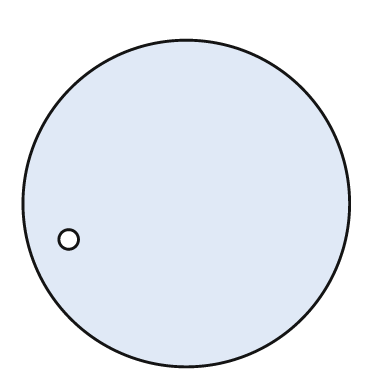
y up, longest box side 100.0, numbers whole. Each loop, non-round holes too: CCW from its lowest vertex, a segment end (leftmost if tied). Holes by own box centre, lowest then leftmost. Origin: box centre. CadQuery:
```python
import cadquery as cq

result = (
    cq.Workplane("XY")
    .moveTo(0.0, 0.0)
    .circle(50.0)
    .moveTo(-36.0, -11.0)
    .circle(3.0)
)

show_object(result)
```